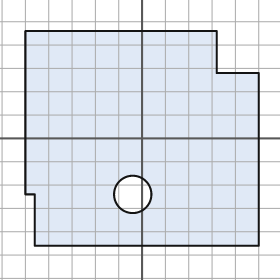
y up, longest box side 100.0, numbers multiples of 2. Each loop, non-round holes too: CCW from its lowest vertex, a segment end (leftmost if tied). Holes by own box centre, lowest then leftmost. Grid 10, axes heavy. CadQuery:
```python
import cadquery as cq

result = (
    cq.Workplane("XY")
    .moveTo(-46.0, -46.0)
    .lineTo(50.0, -46.0)
    .lineTo(50.0, 28.0)
    .lineTo(32.0, 28.0)
    .lineTo(32.0, 46.0)
    .lineTo(-50.0, 46.0)
    .lineTo(-50.0, -24.0)
    .lineTo(-46.0, -24.0)
    .close()
    .moveTo(-4.0, -24.0)
    .circle(8.0)
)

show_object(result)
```